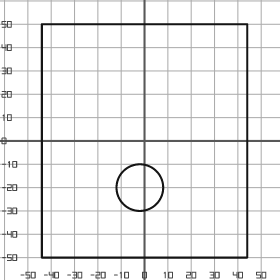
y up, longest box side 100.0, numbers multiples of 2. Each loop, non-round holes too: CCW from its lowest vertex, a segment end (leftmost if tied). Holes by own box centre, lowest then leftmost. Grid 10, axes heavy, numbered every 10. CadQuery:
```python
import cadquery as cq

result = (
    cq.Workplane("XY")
    .moveTo(-44.0, -50.0)
    .lineTo(44.0, -50.0)
    .lineTo(44.0, 50.0)
    .lineTo(-44.0, 50.0)
    .close()
    .moveTo(-2.0, -20.0)
    .circle(10.0)
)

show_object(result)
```